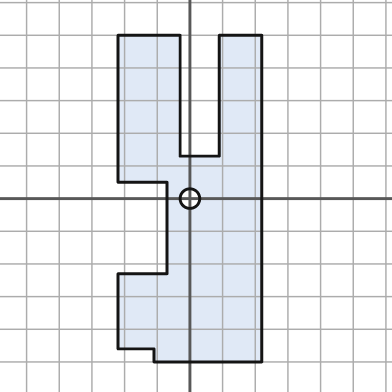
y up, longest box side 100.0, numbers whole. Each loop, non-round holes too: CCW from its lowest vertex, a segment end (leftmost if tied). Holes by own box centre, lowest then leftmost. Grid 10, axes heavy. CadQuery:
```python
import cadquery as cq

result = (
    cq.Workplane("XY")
    .moveTo(-11.0, -50.0)
    .lineTo(22.0, -50.0)
    .lineTo(22.0, 50.0)
    .lineTo(9.0, 50.0)
    .lineTo(9.0, 13.0)
    .lineTo(-3.0, 13.0)
    .lineTo(-3.0, 50.0)
    .lineTo(-22.0, 50.0)
    .lineTo(-22.0, 5.0)
    .lineTo(-7.0, 5.0)
    .lineTo(-7.0, -23.0)
    .lineTo(-22.0, -23.0)
    .lineTo(-22.0, -46.0)
    .lineTo(-11.0, -46.0)
    .close()
    .moveTo(0.0, 0.0)
    .circle(3.0)
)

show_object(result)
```